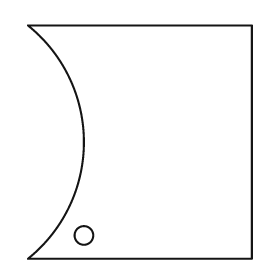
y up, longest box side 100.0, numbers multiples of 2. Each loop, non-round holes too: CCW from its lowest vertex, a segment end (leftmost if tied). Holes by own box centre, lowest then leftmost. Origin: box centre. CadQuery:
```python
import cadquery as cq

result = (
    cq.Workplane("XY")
    .moveTo(-48.0, -50.0)
    .lineTo(48.0, -50.0)
    .lineTo(48.0, 50.0)
    .lineTo(-48.0, 50.0)
    .threePointArc((-24.0, 0.0), (-48.0, -50.0))
    .close()
    .moveTo(-24.0, -40.0)
    .circle(4.0)
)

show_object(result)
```